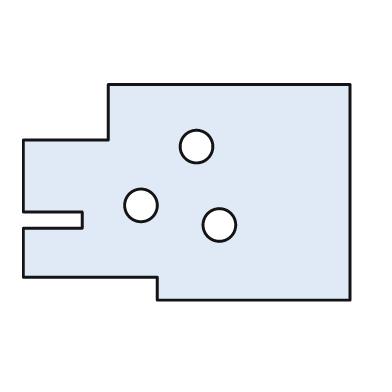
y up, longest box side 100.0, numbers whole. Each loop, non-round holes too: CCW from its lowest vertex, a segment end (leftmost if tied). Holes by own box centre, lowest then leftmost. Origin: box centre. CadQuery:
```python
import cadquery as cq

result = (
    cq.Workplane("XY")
    .moveTo(-9.0, -33.0)
    .lineTo(50.0, -33.0)
    .lineTo(50.0, 33.0)
    .lineTo(-24.0, 33.0)
    .lineTo(-24.0, 16.0)
    .lineTo(-50.0, 16.0)
    .lineTo(-50.0, -6.0)
    .lineTo(-32.0, -6.0)
    .lineTo(-32.0, -11.0)
    .lineTo(-50.0, -11.0)
    .lineTo(-50.0, -26.0)
    .lineTo(-9.0, -26.0)
    .close()
    .moveTo(10.0, -10.0)
    .circle(5.0)
    .moveTo(-14.0, -4.0)
    .circle(5.0)
    .moveTo(3.0, 14.0)
    .circle(5.0)
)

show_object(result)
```